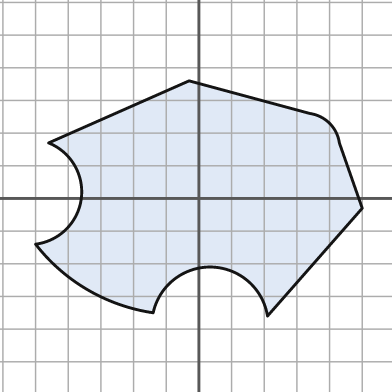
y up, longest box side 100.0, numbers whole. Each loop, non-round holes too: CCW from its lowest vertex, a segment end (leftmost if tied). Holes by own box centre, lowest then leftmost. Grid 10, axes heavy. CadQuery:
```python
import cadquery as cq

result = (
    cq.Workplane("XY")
    .moveTo(21.0, -36.0)
    .lineTo(50.0, -3.0)
    .lineTo(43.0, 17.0)
    .threePointArc((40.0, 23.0), (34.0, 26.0))
    .lineTo(-3.0, 36.0)
    .lineTo(-46.0, 17.0)
    .threePointArc((-36.0, 0.0), (-50.0, -14.0))
    .threePointArc((-34.0, -28.0), (-14.0, -35.0))
    .threePointArc((4.0, -21.0), (21.0, -36.0))
    .close()
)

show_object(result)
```